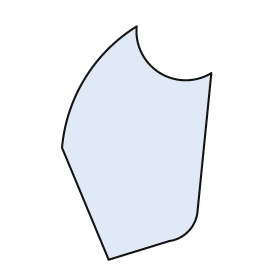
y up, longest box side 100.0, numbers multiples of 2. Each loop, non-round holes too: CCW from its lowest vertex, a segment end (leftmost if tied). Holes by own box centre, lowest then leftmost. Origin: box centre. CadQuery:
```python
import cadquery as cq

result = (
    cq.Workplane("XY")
    .moveTo(-12.0, -50.0)
    .lineTo(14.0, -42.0)
    .threePointArc((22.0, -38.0), (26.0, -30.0))
    .lineTo(32.0, 30.0)
    .threePointArc((10.0, 30.0), (0.0, 50.0))
    .threePointArc((-22.0, 28.0), (-32.0, -2.0))
    .close()
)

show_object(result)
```